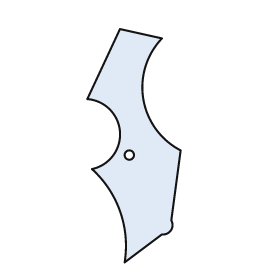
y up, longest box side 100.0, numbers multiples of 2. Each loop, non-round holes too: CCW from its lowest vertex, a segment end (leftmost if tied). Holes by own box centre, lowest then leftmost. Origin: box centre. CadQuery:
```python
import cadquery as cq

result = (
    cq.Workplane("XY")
    .moveTo(-4.0, -50.0)
    .lineTo(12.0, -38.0)
    .threePointArc((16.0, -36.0), (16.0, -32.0))
    .lineTo(20.0, -2.0)
    .threePointArc((4.0, 20.0), (12.0, 46.0))
    .lineTo(-6.0, 50.0)
    .lineTo(-20.0, 20.0)
    .threePointArc((-6.0, 6.0), (-18.0, -10.0))
    .threePointArc((-6.0, -28.0), (-4.0, -50.0))
    .close()
    .moveTo(-2.0, -4.0)
    .circle(2.0)
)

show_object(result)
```